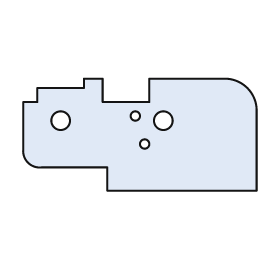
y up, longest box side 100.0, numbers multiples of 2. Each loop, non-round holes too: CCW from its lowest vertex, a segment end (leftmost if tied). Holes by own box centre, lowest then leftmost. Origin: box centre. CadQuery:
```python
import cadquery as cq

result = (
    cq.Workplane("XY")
    .moveTo(-14.0, -24.0)
    .lineTo(50.0, -24.0)
    .lineTo(50.0, 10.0)
    .threePointArc((46.0, 20.0), (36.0, 24.0))
    .lineTo(4.0, 24.0)
    .lineTo(4.0, 14.0)
    .lineTo(-16.0, 14.0)
    .lineTo(-16.0, 24.0)
    .lineTo(-24.0, 24.0)
    .lineTo(-24.0, 20.0)
    .lineTo(-44.0, 20.0)
    .lineTo(-44.0, 14.0)
    .lineTo(-50.0, 14.0)
    .lineTo(-50.0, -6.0)
    .threePointArc((-48.0, -12.0), (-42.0, -14.0))
    .lineTo(-14.0, -14.0)
    .close()
    .moveTo(2.0, -4.0)
    .circle(2.0)
    .moveTo(-34.0, 6.0)
    .circle(4.0)
    .moveTo(10.0, 6.0)
    .circle(4.0)
    .moveTo(-2.0, 8.0)
    .circle(2.0)
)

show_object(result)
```